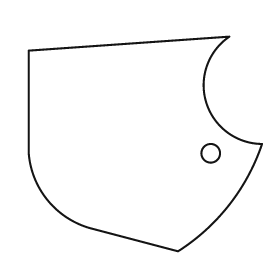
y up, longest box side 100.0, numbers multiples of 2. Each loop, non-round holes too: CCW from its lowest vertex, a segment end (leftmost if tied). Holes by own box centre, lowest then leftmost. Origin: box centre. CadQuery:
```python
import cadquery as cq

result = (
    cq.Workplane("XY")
    .moveTo(14.0, -46.0)
    .threePointArc((36.0, -26.0), (50.0, 0.0))
    .threePointArc((26.0, 18.0), (36.0, 46.0))
    .lineTo(-50.0, 40.0)
    .lineTo(-50.0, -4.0)
    .threePointArc((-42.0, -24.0), (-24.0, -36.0))
    .close()
    .moveTo(28.0, -4.0)
    .circle(4.0)
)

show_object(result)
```